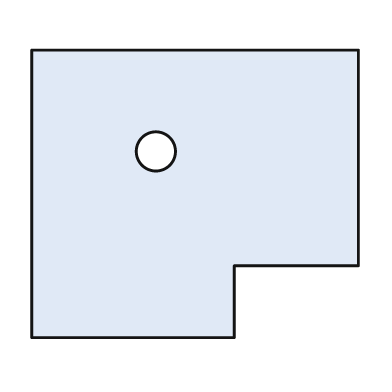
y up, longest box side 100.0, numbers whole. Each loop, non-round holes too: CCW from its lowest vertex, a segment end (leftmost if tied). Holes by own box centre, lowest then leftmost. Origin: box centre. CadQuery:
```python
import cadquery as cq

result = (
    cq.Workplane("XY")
    .moveTo(-50.0, -44.0)
    .lineTo(12.0, -44.0)
    .lineTo(12.0, -22.0)
    .lineTo(50.0, -22.0)
    .lineTo(50.0, 44.0)
    .lineTo(-50.0, 44.0)
    .close()
    .moveTo(-12.0, 13.0)
    .circle(6.0)
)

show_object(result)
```